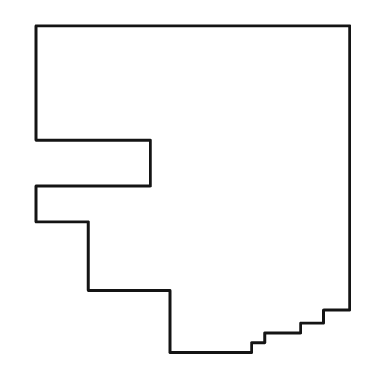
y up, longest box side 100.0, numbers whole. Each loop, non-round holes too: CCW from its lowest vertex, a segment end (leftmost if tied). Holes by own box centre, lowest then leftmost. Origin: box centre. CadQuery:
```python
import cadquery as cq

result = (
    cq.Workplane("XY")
    .moveTo(-7.0, -50.0)
    .lineTo(18.0, -50.0)
    .lineTo(18.0, -47.0)
    .lineTo(22.0, -47.0)
    .lineTo(22.0, -44.0)
    .lineTo(33.0, -44.0)
    .lineTo(33.0, -41.0)
    .lineTo(40.0, -41.0)
    .lineTo(40.0, -37.0)
    .lineTo(48.0, -37.0)
    .lineTo(48.0, 50.0)
    .lineTo(-48.0, 50.0)
    .lineTo(-48.0, 15.0)
    .lineTo(-13.0, 15.0)
    .lineTo(-13.0, 1.0)
    .lineTo(-48.0, 1.0)
    .lineTo(-48.0, -10.0)
    .lineTo(-32.0, -10.0)
    .lineTo(-32.0, -31.0)
    .lineTo(-7.0, -31.0)
    .close()
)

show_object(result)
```